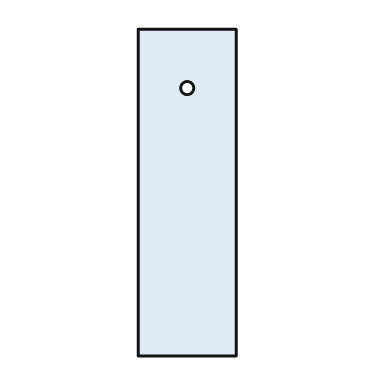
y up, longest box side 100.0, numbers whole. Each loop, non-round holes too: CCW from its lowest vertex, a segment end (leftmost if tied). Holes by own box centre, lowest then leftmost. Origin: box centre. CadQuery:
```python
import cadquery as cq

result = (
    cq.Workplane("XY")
    .moveTo(-15.0, -50.0)
    .lineTo(15.0, -50.0)
    .lineTo(15.0, 50.0)
    .lineTo(-15.0, 50.0)
    .close()
    .moveTo(0.0, 32.0)
    .circle(2.0)
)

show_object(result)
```